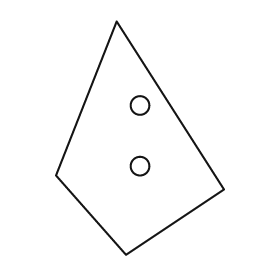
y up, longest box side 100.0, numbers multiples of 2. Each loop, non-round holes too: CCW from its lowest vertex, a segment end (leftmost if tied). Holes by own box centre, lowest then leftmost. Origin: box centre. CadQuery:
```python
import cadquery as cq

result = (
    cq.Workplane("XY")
    .moveTo(-6.0, -50.0)
    .lineTo(36.0, -22.0)
    .lineTo(-10.0, 50.0)
    .lineTo(-36.0, -16.0)
    .close()
    .moveTo(0.0, -12.0)
    .circle(4.0)
    .moveTo(0.0, 14.0)
    .circle(4.0)
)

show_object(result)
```